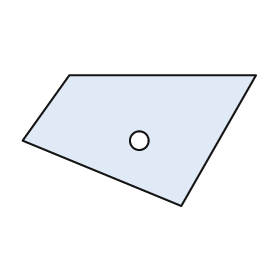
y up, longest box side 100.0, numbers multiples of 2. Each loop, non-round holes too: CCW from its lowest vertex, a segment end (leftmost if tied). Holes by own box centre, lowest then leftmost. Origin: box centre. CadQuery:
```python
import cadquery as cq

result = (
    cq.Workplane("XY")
    .moveTo(18.0, -28.0)
    .lineTo(50.0, 28.0)
    .lineTo(-30.0, 28.0)
    .lineTo(-50.0, 0.0)
    .close()
    .moveTo(0.0, 0.0)
    .circle(4.0)
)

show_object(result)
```